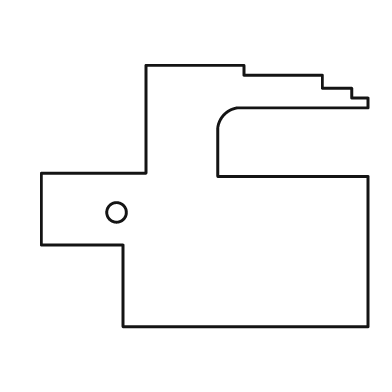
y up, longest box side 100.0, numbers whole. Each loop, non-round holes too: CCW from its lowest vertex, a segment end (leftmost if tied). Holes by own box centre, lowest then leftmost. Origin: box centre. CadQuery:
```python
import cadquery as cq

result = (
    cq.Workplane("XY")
    .moveTo(-25.0, -40.0)
    .lineTo(50.0, -40.0)
    .lineTo(50.0, 6.0)
    .lineTo(4.0, 6.0)
    .lineTo(4.0, 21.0)
    .threePointArc((6.0, 25.0), (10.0, 27.0))
    .lineTo(50.0, 27.0)
    .lineTo(50.0, 30.0)
    .lineTo(45.0, 30.0)
    .lineTo(45.0, 33.0)
    .lineTo(36.0, 33.0)
    .lineTo(36.0, 37.0)
    .lineTo(12.0, 37.0)
    .lineTo(12.0, 40.0)
    .lineTo(-18.0, 40.0)
    .lineTo(-18.0, 7.0)
    .lineTo(-50.0, 7.0)
    .lineTo(-50.0, -15.0)
    .lineTo(-25.0, -15.0)
    .close()
    .moveTo(-27.0, -5.0)
    .circle(3.0)
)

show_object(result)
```